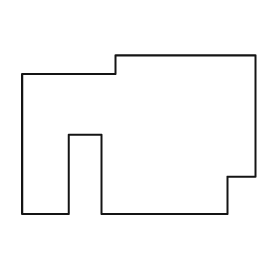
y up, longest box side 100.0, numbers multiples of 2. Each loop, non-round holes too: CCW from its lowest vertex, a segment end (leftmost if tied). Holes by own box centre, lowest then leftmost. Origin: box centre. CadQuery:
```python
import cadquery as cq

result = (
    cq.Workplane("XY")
    .moveTo(-50.0, -34.0)
    .lineTo(-30.0, -34.0)
    .lineTo(-30.0, 0.0)
    .lineTo(-16.0, 0.0)
    .lineTo(-16.0, -34.0)
    .lineTo(38.0, -34.0)
    .lineTo(38.0, -18.0)
    .lineTo(50.0, -18.0)
    .lineTo(50.0, 34.0)
    .lineTo(-10.0, 34.0)
    .lineTo(-10.0, 26.0)
    .lineTo(-50.0, 26.0)
    .close()
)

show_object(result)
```